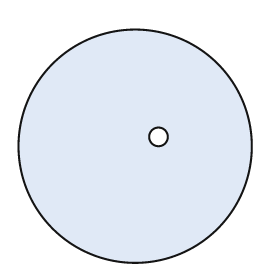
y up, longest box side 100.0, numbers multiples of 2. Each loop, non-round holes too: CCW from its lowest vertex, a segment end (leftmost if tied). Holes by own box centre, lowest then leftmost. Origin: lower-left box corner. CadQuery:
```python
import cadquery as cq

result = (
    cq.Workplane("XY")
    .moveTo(50.0, 50.0)
    .circle(50.0)
    .moveTo(60.0, 54.0)
    .circle(4.0)
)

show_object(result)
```